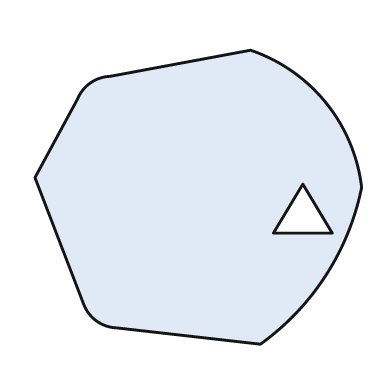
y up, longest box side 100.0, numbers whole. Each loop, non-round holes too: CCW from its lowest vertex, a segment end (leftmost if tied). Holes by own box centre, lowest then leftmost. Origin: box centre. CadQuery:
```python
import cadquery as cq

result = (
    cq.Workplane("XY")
    .moveTo(19.0, -45.0)
    .threePointArc((39.0, -24.0), (50.0, 3.0))
    .threePointArc((39.0, 29.0), (16.0, 45.0))
    .lineTo(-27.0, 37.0)
    .threePointArc((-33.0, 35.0), (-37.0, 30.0))
    .lineTo(-50.0, 6.0)
    .lineTo(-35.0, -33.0)
    .threePointArc((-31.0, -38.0), (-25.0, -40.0))
    .close()
    .moveTo(23.0, -11.0)
    .lineTo(41.0, -11.0)
    .lineTo(32.0, 4.0)
    .close()
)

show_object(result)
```